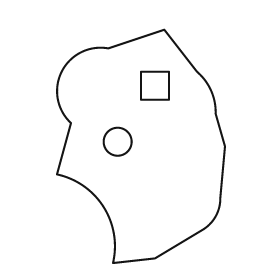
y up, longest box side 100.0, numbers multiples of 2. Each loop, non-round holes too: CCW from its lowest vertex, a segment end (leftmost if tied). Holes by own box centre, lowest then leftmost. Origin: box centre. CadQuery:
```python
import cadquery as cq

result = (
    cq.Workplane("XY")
    .moveTo(-12.0, -50.0)
    .lineTo(6.0, -48.0)
    .lineTo(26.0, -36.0)
    .threePointArc((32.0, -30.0), (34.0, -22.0))
    .lineTo(36.0, 0.0)
    .lineTo(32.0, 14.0)
    .threePointArc((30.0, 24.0), (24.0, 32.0))
    .lineTo(10.0, 50.0)
    .lineTo(-14.0, 42.0)
    .threePointArc((-34.0, 32.0), (-30.0, 10.0))
    .lineTo(-36.0, -12.0)
    .threePointArc((-16.0, -26.0), (-12.0, -50.0))
    .close()
    .moveTo(-10.0, 2.0)
    .circle(6.0)
    .moveTo(0.0, 20.0)
    .lineTo(12.0, 20.0)
    .lineTo(12.0, 32.0)
    .lineTo(0.0, 32.0)
    .close()
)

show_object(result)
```